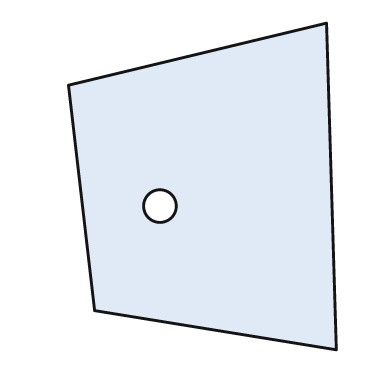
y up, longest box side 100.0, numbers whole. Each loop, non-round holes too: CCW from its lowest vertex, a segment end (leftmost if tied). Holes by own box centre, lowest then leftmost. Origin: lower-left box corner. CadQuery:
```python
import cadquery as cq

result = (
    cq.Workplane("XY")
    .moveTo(82.0, 0.0)
    .lineTo(79.0, 100.0)
    .lineTo(0.0, 81.0)
    .lineTo(8.0, 12.0)
    .close()
    .moveTo(28.0, 44.0)
    .circle(5.0)
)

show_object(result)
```